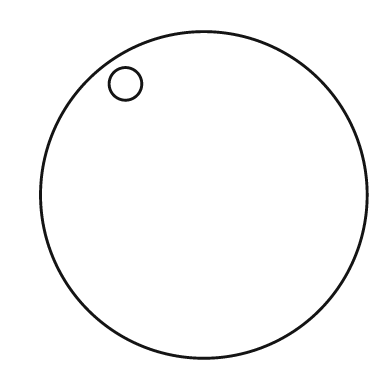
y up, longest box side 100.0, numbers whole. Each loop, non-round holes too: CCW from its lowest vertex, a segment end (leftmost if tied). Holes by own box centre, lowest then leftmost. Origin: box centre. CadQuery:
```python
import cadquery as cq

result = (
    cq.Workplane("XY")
    .moveTo(0.0, 0.0)
    .circle(50.0)
    .moveTo(-24.0, 34.0)
    .circle(5.0)
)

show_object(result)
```